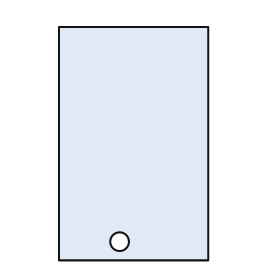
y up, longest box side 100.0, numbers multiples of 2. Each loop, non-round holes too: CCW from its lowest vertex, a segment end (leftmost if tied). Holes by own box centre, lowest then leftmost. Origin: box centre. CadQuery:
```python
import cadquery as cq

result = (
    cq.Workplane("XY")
    .moveTo(-32.0, -50.0)
    .lineTo(32.0, -50.0)
    .lineTo(32.0, 50.0)
    .lineTo(-32.0, 50.0)
    .close()
    .moveTo(-6.0, -42.0)
    .circle(4.0)
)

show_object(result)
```